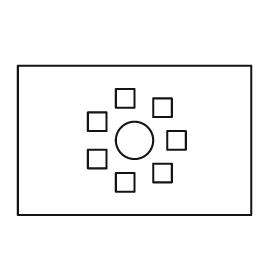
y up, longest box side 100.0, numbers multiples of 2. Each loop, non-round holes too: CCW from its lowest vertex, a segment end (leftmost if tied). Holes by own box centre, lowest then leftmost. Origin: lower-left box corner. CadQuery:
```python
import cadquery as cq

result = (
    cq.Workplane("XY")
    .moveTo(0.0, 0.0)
    .lineTo(100.0, 0.0)
    .lineTo(100.0, 64.0)
    .lineTo(0.0, 64.0)
    .close()
    .moveTo(42.0, 10.0)
    .lineTo(50.0, 10.0)
    .lineTo(50.0, 18.0)
    .lineTo(42.0, 18.0)
    .close()
    .moveTo(58.0, 14.0)
    .lineTo(66.0, 14.0)
    .lineTo(66.0, 22.0)
    .lineTo(58.0, 22.0)
    .close()
    .moveTo(30.0, 20.0)
    .lineTo(38.0, 20.0)
    .lineTo(38.0, 28.0)
    .lineTo(30.0, 28.0)
    .close()
    .moveTo(50.0, 32.0)
    .circle(8.0)
    .moveTo(64.0, 28.0)
    .lineTo(72.0, 28.0)
    .lineTo(72.0, 36.0)
    .lineTo(64.0, 36.0)
    .close()
    .moveTo(30.0, 36.0)
    .lineTo(38.0, 36.0)
    .lineTo(38.0, 44.0)
    .lineTo(30.0, 44.0)
    .close()
    .moveTo(58.0, 42.0)
    .lineTo(66.0, 42.0)
    .lineTo(66.0, 50.0)
    .lineTo(58.0, 50.0)
    .close()
    .moveTo(42.0, 46.0)
    .lineTo(50.0, 46.0)
    .lineTo(50.0, 54.0)
    .lineTo(42.0, 54.0)
    .close()
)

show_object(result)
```